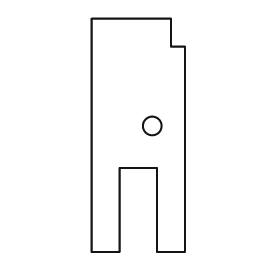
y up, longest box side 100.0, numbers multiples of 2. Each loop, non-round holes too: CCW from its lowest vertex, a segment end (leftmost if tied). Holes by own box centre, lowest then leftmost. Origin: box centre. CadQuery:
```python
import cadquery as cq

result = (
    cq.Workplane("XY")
    .moveTo(-20.0, -50.0)
    .lineTo(-8.0, -50.0)
    .lineTo(-8.0, -14.0)
    .lineTo(8.0, -14.0)
    .lineTo(8.0, -50.0)
    .lineTo(20.0, -50.0)
    .lineTo(20.0, 38.0)
    .lineTo(14.0, 38.0)
    .lineTo(14.0, 50.0)
    .lineTo(-20.0, 50.0)
    .close()
    .moveTo(6.0, 4.0)
    .circle(4.0)
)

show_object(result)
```